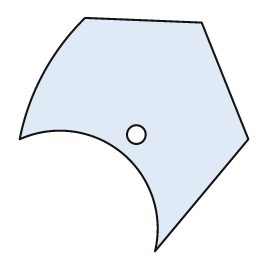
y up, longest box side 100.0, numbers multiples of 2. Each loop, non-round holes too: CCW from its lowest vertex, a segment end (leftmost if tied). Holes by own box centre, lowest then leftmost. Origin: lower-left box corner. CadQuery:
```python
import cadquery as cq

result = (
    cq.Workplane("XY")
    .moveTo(58.0, 0.0)
    .lineTo(98.0, 48.0)
    .lineTo(78.0, 98.0)
    .lineTo(28.0, 100.0)
    .threePointArc((10.0, 76.0), (0.0, 48.0))
    .threePointArc((44.0, 42.0), (58.0, 0.0))
    .close()
    .moveTo(50.0, 50.0)
    .circle(4.0)
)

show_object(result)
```